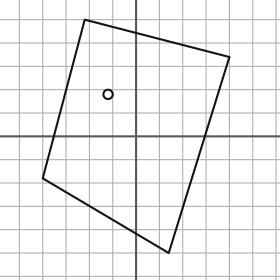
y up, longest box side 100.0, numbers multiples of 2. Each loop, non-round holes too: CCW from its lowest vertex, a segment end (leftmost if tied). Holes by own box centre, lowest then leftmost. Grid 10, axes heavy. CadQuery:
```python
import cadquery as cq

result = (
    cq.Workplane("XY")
    .moveTo(14.0, -50.0)
    .lineTo(40.0, 34.0)
    .lineTo(-22.0, 50.0)
    .lineTo(-40.0, -18.0)
    .close()
    .moveTo(-12.0, 18.0)
    .circle(2.0)
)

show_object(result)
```